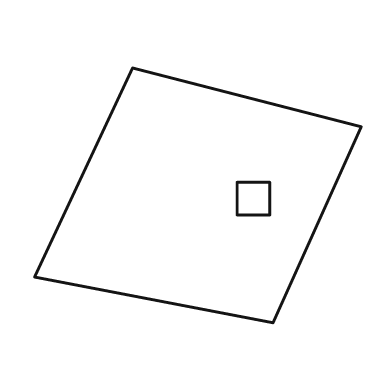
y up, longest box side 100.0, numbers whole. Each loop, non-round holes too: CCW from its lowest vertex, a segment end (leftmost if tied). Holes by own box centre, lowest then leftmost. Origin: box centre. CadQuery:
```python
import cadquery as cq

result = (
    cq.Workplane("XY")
    .moveTo(23.0, -39.0)
    .lineTo(50.0, 21.0)
    .lineTo(-20.0, 39.0)
    .lineTo(-50.0, -25.0)
    .close()
    .moveTo(12.0, -6.0)
    .lineTo(22.0, -6.0)
    .lineTo(22.0, 4.0)
    .lineTo(12.0, 4.0)
    .close()
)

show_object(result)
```